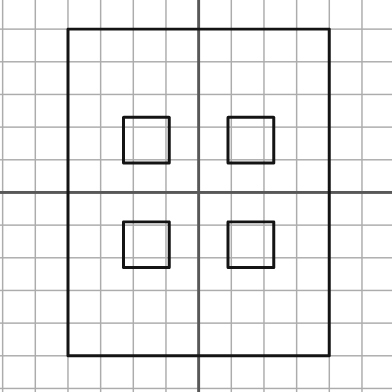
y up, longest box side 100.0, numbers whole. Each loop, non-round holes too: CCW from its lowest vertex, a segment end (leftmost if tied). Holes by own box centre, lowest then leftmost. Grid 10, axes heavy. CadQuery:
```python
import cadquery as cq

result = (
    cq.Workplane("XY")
    .moveTo(-40.0, -50.0)
    .lineTo(40.0, -50.0)
    .lineTo(40.0, 50.0)
    .lineTo(-40.0, 50.0)
    .close()
    .moveTo(-23.0, -23.0)
    .lineTo(-9.0, -23.0)
    .lineTo(-9.0, -9.0)
    .lineTo(-23.0, -9.0)
    .close()
    .moveTo(9.0, -23.0)
    .lineTo(23.0, -23.0)
    .lineTo(23.0, -9.0)
    .lineTo(9.0, -9.0)
    .close()
    .moveTo(-23.0, 9.0)
    .lineTo(-9.0, 9.0)
    .lineTo(-9.0, 23.0)
    .lineTo(-23.0, 23.0)
    .close()
    .moveTo(9.0, 9.0)
    .lineTo(23.0, 9.0)
    .lineTo(23.0, 23.0)
    .lineTo(9.0, 23.0)
    .close()
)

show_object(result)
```